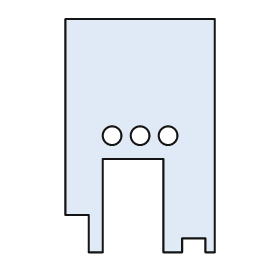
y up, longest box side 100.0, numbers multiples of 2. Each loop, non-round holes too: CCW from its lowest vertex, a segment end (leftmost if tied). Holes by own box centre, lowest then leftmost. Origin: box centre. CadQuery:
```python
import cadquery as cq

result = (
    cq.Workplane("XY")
    .moveTo(-22.0, -50.0)
    .lineTo(-16.0, -50.0)
    .lineTo(-16.0, -10.0)
    .lineTo(10.0, -10.0)
    .lineTo(10.0, -50.0)
    .lineTo(18.0, -50.0)
    .lineTo(18.0, -44.0)
    .lineTo(28.0, -44.0)
    .lineTo(28.0, -50.0)
    .lineTo(32.0, -50.0)
    .lineTo(32.0, 50.0)
    .lineTo(-32.0, 50.0)
    .lineTo(-32.0, -34.0)
    .lineTo(-22.0, -34.0)
    .close()
    .moveTo(-12.0, 0.0)
    .circle(4.0)
    .moveTo(0.0, 0.0)
    .circle(4.0)
    .moveTo(12.0, 0.0)
    .circle(4.0)
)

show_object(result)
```